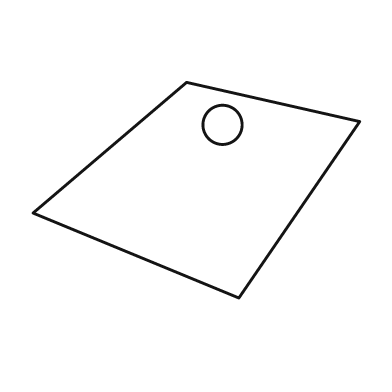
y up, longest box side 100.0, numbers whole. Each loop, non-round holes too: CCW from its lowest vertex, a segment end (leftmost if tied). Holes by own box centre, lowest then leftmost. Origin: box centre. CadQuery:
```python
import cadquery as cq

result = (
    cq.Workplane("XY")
    .moveTo(13.0, -33.0)
    .lineTo(50.0, 21.0)
    .lineTo(-3.0, 33.0)
    .lineTo(-50.0, -7.0)
    .close()
    .moveTo(8.0, 20.0)
    .circle(6.0)
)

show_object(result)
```